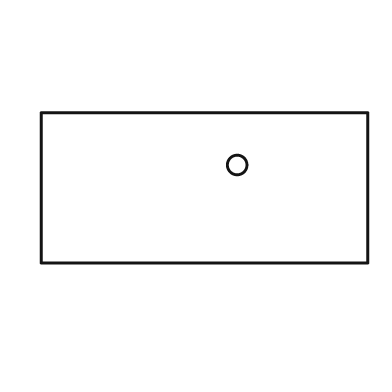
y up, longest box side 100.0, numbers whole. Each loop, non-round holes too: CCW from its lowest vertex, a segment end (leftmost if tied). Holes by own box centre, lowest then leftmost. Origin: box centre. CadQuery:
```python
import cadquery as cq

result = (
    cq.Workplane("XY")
    .moveTo(-50.0, -23.0)
    .lineTo(50.0, -23.0)
    .lineTo(50.0, 23.0)
    .lineTo(-50.0, 23.0)
    .close()
    .moveTo(10.0, 7.0)
    .circle(3.0)
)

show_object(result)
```